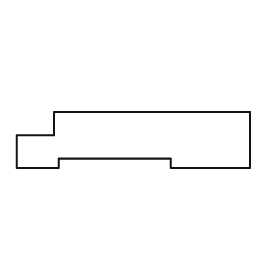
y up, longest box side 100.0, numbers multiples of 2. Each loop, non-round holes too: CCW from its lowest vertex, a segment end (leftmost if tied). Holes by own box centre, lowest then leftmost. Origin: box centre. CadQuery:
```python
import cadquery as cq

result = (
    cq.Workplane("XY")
    .moveTo(-50.0, -12.0)
    .lineTo(-32.0, -12.0)
    .lineTo(-32.0, -8.0)
    .lineTo(16.0, -8.0)
    .lineTo(16.0, -12.0)
    .lineTo(50.0, -12.0)
    .lineTo(50.0, 12.0)
    .lineTo(-34.0, 12.0)
    .lineTo(-34.0, 2.0)
    .lineTo(-50.0, 2.0)
    .close()
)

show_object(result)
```